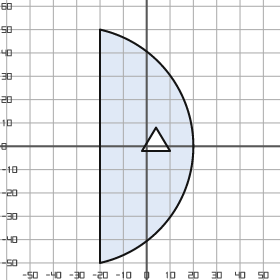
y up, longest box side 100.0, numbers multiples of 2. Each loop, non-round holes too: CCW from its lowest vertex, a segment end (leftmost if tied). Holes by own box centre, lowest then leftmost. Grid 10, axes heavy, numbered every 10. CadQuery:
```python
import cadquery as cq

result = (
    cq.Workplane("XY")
    .moveTo(-20.0, -50.0)
    .threePointArc((20.0, 0.0), (-20.0, 50.0))
    .close()
    .moveTo(-2.0, -2.0)
    .lineTo(10.0, -2.0)
    .lineTo(4.0, 8.0)
    .close()
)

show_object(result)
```